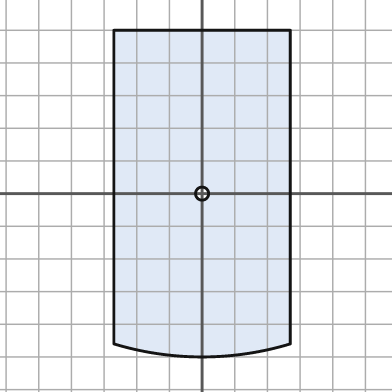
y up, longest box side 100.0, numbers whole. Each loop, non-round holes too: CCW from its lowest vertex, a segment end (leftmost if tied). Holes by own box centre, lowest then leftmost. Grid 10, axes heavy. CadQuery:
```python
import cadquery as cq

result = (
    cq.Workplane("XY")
    .moveTo(-27.0, -46.0)
    .threePointArc((0.0, -50.0), (27.0, -46.0))
    .lineTo(27.0, 50.0)
    .lineTo(-27.0, 50.0)
    .close()
    .moveTo(0.0, 0.0)
    .circle(2.0)
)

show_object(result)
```